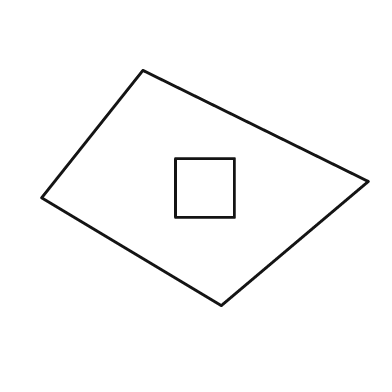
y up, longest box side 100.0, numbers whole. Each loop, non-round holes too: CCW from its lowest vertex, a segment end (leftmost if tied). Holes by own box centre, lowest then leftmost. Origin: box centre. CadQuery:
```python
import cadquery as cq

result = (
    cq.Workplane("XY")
    .moveTo(5.0, -36.0)
    .lineTo(50.0, 2.0)
    .lineTo(-19.0, 36.0)
    .lineTo(-50.0, -3.0)
    .close()
    .moveTo(-9.0, -9.0)
    .lineTo(9.0, -9.0)
    .lineTo(9.0, 9.0)
    .lineTo(-9.0, 9.0)
    .close()
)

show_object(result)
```